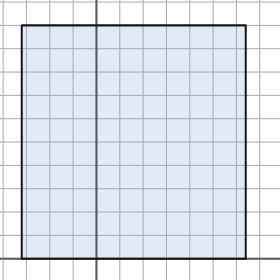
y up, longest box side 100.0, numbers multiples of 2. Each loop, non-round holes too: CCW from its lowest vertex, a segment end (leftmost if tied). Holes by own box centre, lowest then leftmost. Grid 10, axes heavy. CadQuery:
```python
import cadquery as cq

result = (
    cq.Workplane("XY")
    .moveTo(-32.0, 0.0)
    .lineTo(64.0, 0.0)
    .lineTo(64.0, 100.0)
    .lineTo(-32.0, 100.0)
    .close()
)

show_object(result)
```